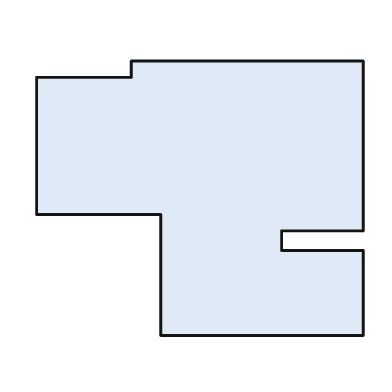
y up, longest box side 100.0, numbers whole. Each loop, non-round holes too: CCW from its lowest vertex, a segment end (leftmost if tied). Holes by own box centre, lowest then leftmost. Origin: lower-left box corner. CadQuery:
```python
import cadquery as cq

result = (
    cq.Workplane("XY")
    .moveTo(38.0, 0.0)
    .lineTo(100.0, 0.0)
    .lineTo(100.0, 26.0)
    .lineTo(75.0, 26.0)
    .lineTo(75.0, 32.0)
    .lineTo(100.0, 32.0)
    .lineTo(100.0, 84.0)
    .lineTo(29.0, 84.0)
    .lineTo(29.0, 79.0)
    .lineTo(0.0, 79.0)
    .lineTo(0.0, 37.0)
    .lineTo(38.0, 37.0)
    .close()
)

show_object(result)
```